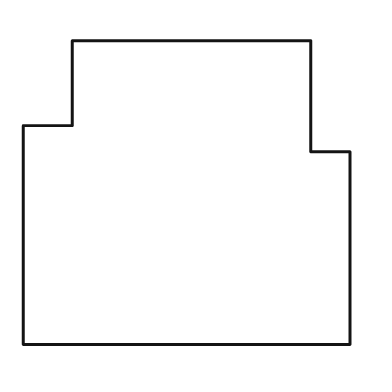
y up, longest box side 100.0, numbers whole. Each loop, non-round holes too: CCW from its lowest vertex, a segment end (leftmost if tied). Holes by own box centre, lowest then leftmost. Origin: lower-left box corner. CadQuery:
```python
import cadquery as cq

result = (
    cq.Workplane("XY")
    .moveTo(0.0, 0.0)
    .lineTo(100.0, 0.0)
    .lineTo(100.0, 59.0)
    .lineTo(88.0, 59.0)
    .lineTo(88.0, 93.0)
    .lineTo(15.0, 93.0)
    .lineTo(15.0, 67.0)
    .lineTo(0.0, 67.0)
    .close()
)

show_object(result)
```